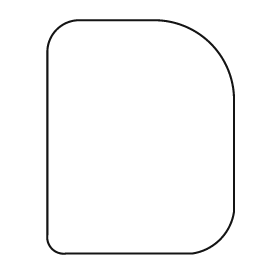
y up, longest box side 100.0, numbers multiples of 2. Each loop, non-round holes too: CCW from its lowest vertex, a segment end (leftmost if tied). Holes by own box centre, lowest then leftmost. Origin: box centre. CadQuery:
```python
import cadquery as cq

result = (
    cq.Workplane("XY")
    .moveTo(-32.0, -50.0)
    .lineTo(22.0, -50.0)
    .threePointArc((34.0, -44.0), (40.0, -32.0))
    .lineTo(40.0, 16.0)
    .threePointArc((30.0, 40.0), (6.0, 50.0))
    .lineTo(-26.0, 50.0)
    .threePointArc((-36.0, 46.0), (-40.0, 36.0))
    .lineTo(-40.0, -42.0)
    .threePointArc((-38.0, -48.0), (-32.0, -50.0))
    .close()
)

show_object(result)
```